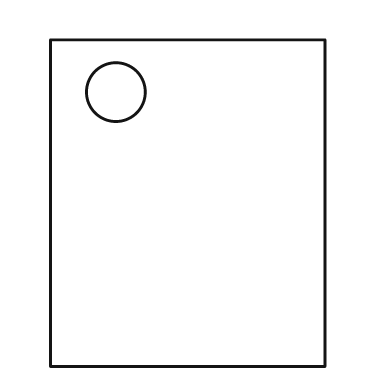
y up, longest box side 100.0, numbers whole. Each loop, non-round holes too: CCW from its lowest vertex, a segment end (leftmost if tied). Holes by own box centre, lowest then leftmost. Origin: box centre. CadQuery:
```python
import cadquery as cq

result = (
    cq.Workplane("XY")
    .moveTo(-42.0, -50.0)
    .lineTo(42.0, -50.0)
    .lineTo(42.0, 50.0)
    .lineTo(-42.0, 50.0)
    .close()
    .moveTo(-22.0, 34.0)
    .circle(9.0)
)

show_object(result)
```